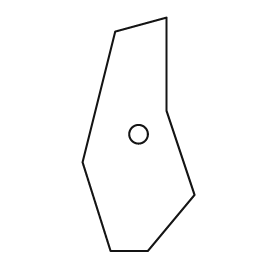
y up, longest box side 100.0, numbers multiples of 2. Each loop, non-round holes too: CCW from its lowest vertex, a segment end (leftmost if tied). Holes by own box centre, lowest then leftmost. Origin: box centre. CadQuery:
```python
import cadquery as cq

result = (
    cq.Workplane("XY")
    .moveTo(-12.0, -50.0)
    .lineTo(4.0, -50.0)
    .lineTo(24.0, -26.0)
    .lineTo(12.0, 10.0)
    .lineTo(12.0, 50.0)
    .lineTo(-10.0, 44.0)
    .lineTo(-24.0, -12.0)
    .close()
    .moveTo(0.0, 0.0)
    .circle(4.0)
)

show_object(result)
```